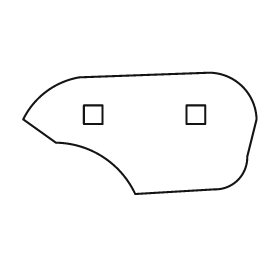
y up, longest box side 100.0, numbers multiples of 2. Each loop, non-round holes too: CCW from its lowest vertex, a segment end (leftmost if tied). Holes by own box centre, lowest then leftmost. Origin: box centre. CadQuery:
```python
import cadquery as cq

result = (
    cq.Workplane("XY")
    .moveTo(-2.0, -26.0)
    .lineTo(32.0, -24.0)
    .threePointArc((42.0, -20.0), (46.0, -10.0))
    .lineTo(50.0, 6.0)
    .threePointArc((44.0, 20.0), (30.0, 26.0))
    .lineTo(-26.0, 24.0)
    .threePointArc((-40.0, 18.0), (-50.0, 6.0))
    .lineTo(-36.0, -4.0)
    .threePointArc((-16.0, -10.0), (-2.0, -26.0))
    .close()
    .moveTo(-24.0, 4.0)
    .lineTo(-16.0, 4.0)
    .lineTo(-16.0, 12.0)
    .lineTo(-24.0, 12.0)
    .close()
    .moveTo(20.0, 4.0)
    .lineTo(28.0, 4.0)
    .lineTo(28.0, 12.0)
    .lineTo(20.0, 12.0)
    .close()
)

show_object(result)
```